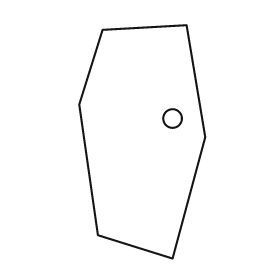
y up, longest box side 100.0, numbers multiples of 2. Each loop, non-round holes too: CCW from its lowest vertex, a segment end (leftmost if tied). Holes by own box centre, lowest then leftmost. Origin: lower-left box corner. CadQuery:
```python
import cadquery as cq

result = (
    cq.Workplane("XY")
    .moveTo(40.0, 0.0)
    .lineTo(54.0, 52.0)
    .lineTo(46.0, 100.0)
    .lineTo(10.0, 98.0)
    .lineTo(0.0, 66.0)
    .lineTo(8.0, 10.0)
    .close()
    .moveTo(40.0, 60.0)
    .circle(4.0)
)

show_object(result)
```